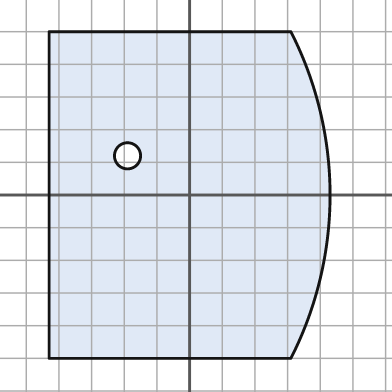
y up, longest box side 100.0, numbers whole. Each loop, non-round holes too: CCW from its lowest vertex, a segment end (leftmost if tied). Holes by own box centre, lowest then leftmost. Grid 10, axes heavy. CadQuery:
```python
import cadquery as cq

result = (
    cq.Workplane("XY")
    .moveTo(-43.0, -50.0)
    .lineTo(31.0, -50.0)
    .threePointArc((43.0, 0.0), (31.0, 50.0))
    .lineTo(-43.0, 50.0)
    .close()
    .moveTo(-19.0, 12.0)
    .circle(4.0)
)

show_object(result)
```